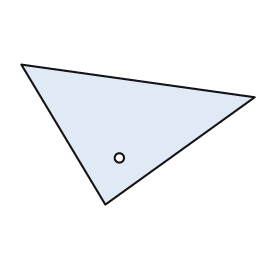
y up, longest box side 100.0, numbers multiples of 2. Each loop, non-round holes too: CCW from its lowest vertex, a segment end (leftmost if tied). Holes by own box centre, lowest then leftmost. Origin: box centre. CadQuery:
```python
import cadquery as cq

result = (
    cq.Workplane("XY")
    .moveTo(-14.0, -30.0)
    .lineTo(50.0, 16.0)
    .lineTo(-50.0, 30.0)
    .close()
    .moveTo(-8.0, -10.0)
    .circle(2.0)
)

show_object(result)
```